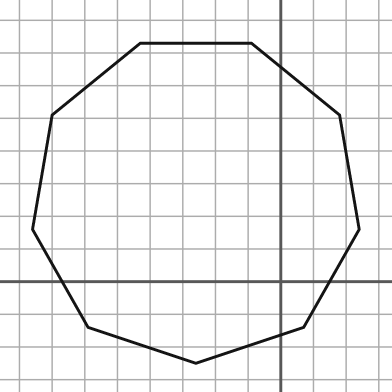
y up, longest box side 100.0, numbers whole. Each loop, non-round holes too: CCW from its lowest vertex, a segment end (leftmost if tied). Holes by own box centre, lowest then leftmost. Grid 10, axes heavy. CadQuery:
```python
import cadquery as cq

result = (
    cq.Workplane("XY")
    .moveTo(-26.0, -25.0)
    .lineTo(7.0, -14.0)
    .lineTo(24.0, 16.0)
    .lineTo(18.0, 51.0)
    .lineTo(-9.0, 73.0)
    .lineTo(-43.0, 73.0)
    .lineTo(-70.0, 51.0)
    .lineTo(-76.0, 16.0)
    .lineTo(-59.0, -14.0)
    .close()
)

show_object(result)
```